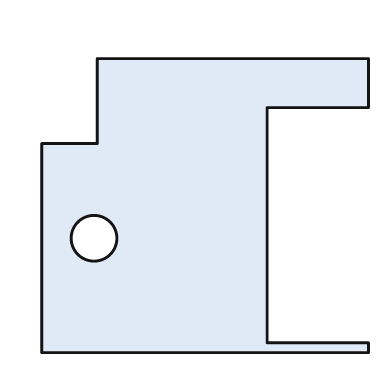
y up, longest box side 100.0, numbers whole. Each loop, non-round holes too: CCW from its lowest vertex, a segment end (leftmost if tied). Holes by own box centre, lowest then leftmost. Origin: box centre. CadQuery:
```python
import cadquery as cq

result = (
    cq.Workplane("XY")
    .moveTo(-50.0, -45.0)
    .lineTo(50.0, -45.0)
    .lineTo(50.0, -42.0)
    .lineTo(19.0, -42.0)
    .lineTo(19.0, 30.0)
    .lineTo(50.0, 30.0)
    .lineTo(50.0, 45.0)
    .lineTo(-33.0, 45.0)
    .lineTo(-33.0, 19.0)
    .lineTo(-50.0, 19.0)
    .close()
    .moveTo(-34.0, -10.0)
    .circle(7.0)
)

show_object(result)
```